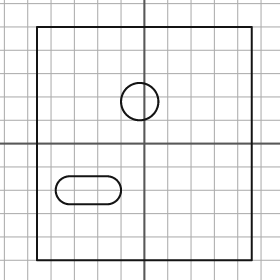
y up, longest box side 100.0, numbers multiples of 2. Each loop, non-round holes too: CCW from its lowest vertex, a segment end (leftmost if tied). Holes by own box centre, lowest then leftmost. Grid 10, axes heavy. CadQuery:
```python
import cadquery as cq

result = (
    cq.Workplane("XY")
    .moveTo(-46.0, -50.0)
    .lineTo(46.0, -50.0)
    .lineTo(46.0, 50.0)
    .lineTo(-46.0, 50.0)
    .close()
    .moveTo(-32.0, -26.0)
    .lineTo(-16.0, -26.0)
    .threePointArc((-10.0, -20.0), (-16.0, -14.0))
    .lineTo(-32.0, -14.0)
    .threePointArc((-38.0, -20.0), (-32.0, -26.0))
    .close()
    .moveTo(-2.0, 18.0)
    .circle(8.0)
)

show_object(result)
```